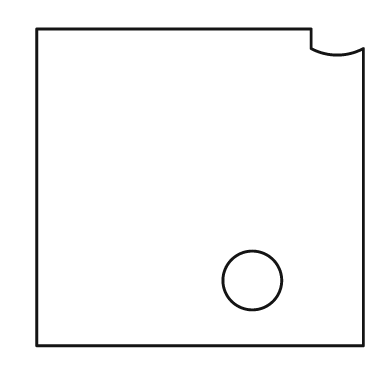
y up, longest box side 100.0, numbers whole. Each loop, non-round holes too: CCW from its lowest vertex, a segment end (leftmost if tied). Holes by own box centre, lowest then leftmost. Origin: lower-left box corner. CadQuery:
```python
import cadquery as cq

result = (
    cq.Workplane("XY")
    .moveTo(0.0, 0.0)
    .lineTo(100.0, 0.0)
    .lineTo(100.0, 91.0)
    .threePointArc((92.0, 89.0), (84.0, 91.0))
    .lineTo(84.0, 97.0)
    .lineTo(0.0, 97.0)
    .close()
    .moveTo(66.0, 20.0)
    .circle(9.0)
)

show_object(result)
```